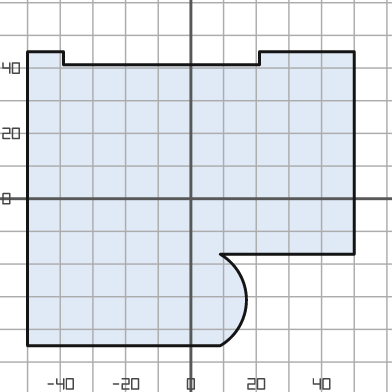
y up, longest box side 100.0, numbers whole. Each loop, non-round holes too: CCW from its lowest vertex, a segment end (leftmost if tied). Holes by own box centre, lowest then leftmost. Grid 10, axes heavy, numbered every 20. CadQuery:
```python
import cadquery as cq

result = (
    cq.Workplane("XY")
    .moveTo(-50.0, -45.0)
    .lineTo(9.0, -45.0)
    .threePointArc((17.0, -31.0), (9.0, -17.0))
    .lineTo(50.0, -17.0)
    .lineTo(50.0, 45.0)
    .lineTo(21.0, 45.0)
    .lineTo(21.0, 41.0)
    .lineTo(-39.0, 41.0)
    .lineTo(-39.0, 45.0)
    .lineTo(-50.0, 45.0)
    .close()
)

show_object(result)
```